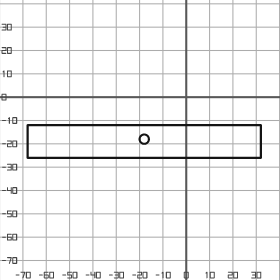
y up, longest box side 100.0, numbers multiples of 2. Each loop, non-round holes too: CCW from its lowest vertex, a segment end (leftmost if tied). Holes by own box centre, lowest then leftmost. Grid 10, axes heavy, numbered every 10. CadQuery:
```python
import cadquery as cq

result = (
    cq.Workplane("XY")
    .moveTo(-68.0, -26.0)
    .lineTo(32.0, -26.0)
    .lineTo(32.0, -12.0)
    .lineTo(-68.0, -12.0)
    .close()
    .moveTo(-18.0, -18.0)
    .circle(2.0)
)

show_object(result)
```